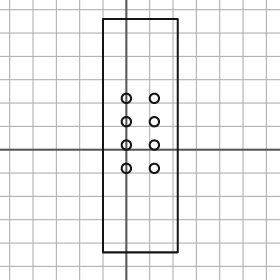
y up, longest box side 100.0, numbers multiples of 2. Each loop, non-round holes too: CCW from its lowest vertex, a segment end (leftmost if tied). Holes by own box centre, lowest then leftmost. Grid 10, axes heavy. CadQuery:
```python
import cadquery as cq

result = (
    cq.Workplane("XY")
    .moveTo(-10.0, -44.0)
    .lineTo(22.0, -44.0)
    .lineTo(22.0, 56.0)
    .lineTo(-10.0, 56.0)
    .close()
    .moveTo(0.0, -8.0)
    .circle(2.0)
    .moveTo(12.0, -8.0)
    .circle(2.0)
    .moveTo(0.0, 2.0)
    .circle(2.0)
    .moveTo(12.0, 2.0)
    .circle(2.0)
    .moveTo(0.0, 12.0)
    .circle(2.0)
    .moveTo(12.0, 12.0)
    .circle(2.0)
    .moveTo(0.0, 22.0)
    .circle(2.0)
    .moveTo(12.0, 22.0)
    .circle(2.0)
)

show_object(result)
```